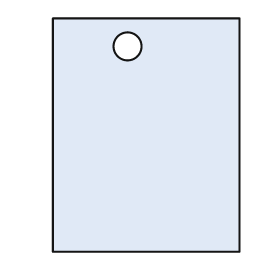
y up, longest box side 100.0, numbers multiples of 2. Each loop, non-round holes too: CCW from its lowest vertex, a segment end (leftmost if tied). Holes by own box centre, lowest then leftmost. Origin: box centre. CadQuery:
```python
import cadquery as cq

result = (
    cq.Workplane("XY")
    .moveTo(-40.0, -50.0)
    .lineTo(40.0, -50.0)
    .lineTo(40.0, 50.0)
    .lineTo(-40.0, 50.0)
    .close()
    .moveTo(-8.0, 38.0)
    .circle(6.0)
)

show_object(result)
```